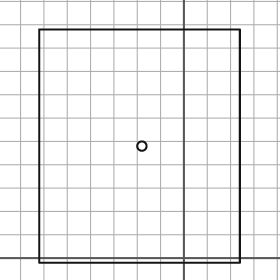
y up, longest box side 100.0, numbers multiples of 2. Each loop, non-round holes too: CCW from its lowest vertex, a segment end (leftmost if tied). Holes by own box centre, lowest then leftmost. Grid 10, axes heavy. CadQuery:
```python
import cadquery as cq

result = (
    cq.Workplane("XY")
    .moveTo(-62.0, -2.0)
    .lineTo(24.0, -2.0)
    .lineTo(24.0, 98.0)
    .lineTo(-62.0, 98.0)
    .close()
    .moveTo(-18.0, 48.0)
    .circle(2.0)
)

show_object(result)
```